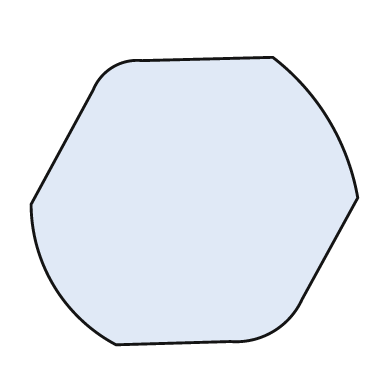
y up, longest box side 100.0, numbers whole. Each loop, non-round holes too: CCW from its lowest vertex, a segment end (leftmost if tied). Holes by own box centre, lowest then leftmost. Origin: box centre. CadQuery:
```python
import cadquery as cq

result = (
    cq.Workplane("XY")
    .moveTo(-24.0, -44.0)
    .lineTo(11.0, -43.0)
    .threePointArc((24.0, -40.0), (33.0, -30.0))
    .lineTo(50.0, 1.0)
    .threePointArc((41.0, 25.0), (24.0, 44.0))
    .lineTo(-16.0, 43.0)
    .threePointArc((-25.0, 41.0), (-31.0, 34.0))
    .lineTo(-50.0, -1.0)
    .threePointArc((-43.0, -26.0), (-24.0, -44.0))
    .close()
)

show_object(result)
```